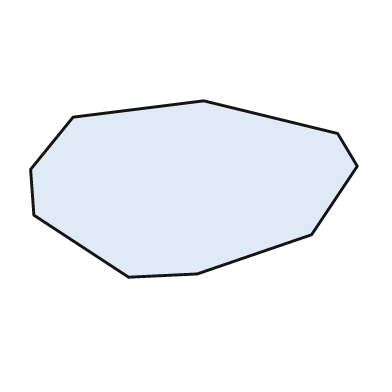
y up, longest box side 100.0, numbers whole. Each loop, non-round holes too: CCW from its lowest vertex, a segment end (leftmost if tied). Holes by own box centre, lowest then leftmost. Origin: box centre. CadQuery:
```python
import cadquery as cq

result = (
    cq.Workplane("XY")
    .moveTo(-20.0, -27.0)
    .lineTo(1.0, -26.0)
    .lineTo(36.0, -14.0)
    .lineTo(50.0, 7.0)
    .lineTo(44.0, 17.0)
    .lineTo(3.0, 27.0)
    .lineTo(-37.0, 22.0)
    .lineTo(-50.0, 6.0)
    .lineTo(-49.0, -8.0)
    .close()
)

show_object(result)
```